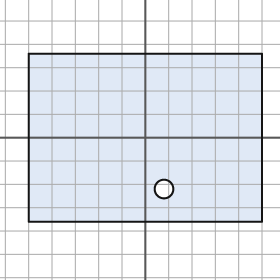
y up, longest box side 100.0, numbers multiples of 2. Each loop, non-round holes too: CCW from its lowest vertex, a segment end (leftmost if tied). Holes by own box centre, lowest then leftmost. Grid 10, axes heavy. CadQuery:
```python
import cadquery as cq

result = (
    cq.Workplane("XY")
    .moveTo(-50.0, -36.0)
    .lineTo(50.0, -36.0)
    .lineTo(50.0, 36.0)
    .lineTo(-50.0, 36.0)
    .close()
    .moveTo(8.0, -22.0)
    .circle(4.0)
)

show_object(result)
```